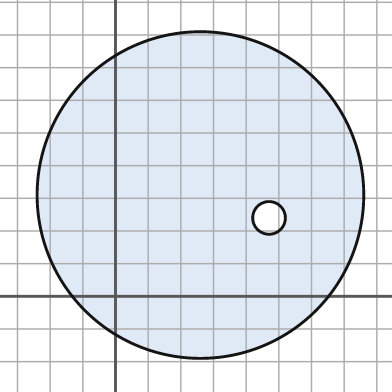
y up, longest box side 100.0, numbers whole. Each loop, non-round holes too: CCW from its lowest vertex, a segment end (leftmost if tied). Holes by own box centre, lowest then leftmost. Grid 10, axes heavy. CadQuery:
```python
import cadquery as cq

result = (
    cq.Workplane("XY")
    .moveTo(26.0, 31.0)
    .circle(50.0)
    .moveTo(47.0, 24.0)
    .circle(5.0)
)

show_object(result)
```